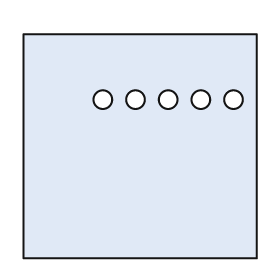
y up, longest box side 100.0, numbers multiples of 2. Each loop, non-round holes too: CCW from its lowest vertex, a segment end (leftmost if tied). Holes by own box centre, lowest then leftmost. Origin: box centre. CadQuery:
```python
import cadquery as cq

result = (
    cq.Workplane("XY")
    .moveTo(-50.0, -48.0)
    .lineTo(50.0, -48.0)
    .lineTo(50.0, 48.0)
    .lineTo(-50.0, 48.0)
    .close()
    .moveTo(-16.0, 20.0)
    .circle(4.0)
    .moveTo(-2.0, 20.0)
    .circle(4.0)
    .moveTo(12.0, 20.0)
    .circle(4.0)
    .moveTo(26.0, 20.0)
    .circle(4.0)
    .moveTo(40.0, 20.0)
    .circle(4.0)
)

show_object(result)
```